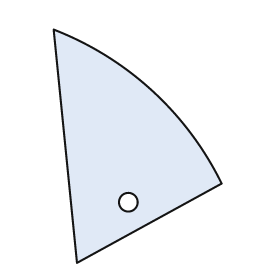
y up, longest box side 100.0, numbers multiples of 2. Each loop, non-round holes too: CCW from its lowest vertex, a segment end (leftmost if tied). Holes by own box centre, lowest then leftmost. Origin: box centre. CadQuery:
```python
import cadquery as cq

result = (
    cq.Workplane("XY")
    .moveTo(-26.0, -50.0)
    .lineTo(36.0, -16.0)
    .threePointArc((6.0, 24.0), (-36.0, 50.0))
    .close()
    .moveTo(-4.0, -24.0)
    .circle(4.0)
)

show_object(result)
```